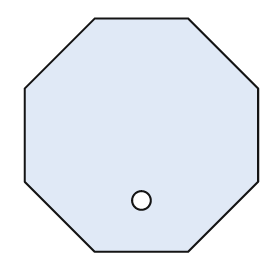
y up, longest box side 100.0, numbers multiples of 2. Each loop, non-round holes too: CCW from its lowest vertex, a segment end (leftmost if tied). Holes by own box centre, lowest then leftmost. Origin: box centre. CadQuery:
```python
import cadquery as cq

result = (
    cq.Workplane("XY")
    .moveTo(-20.0, -50.0)
    .lineTo(20.0, -50.0)
    .lineTo(50.0, -20.0)
    .lineTo(50.0, 20.0)
    .lineTo(20.0, 50.0)
    .lineTo(-20.0, 50.0)
    .lineTo(-50.0, 20.0)
    .lineTo(-50.0, -20.0)
    .close()
    .moveTo(0.0, -28.0)
    .circle(4.0)
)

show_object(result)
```